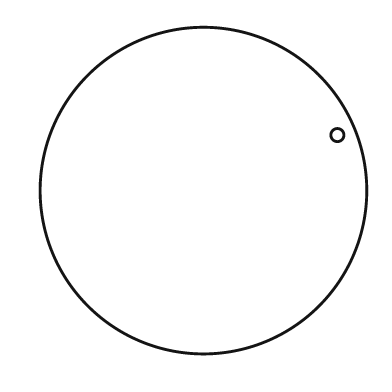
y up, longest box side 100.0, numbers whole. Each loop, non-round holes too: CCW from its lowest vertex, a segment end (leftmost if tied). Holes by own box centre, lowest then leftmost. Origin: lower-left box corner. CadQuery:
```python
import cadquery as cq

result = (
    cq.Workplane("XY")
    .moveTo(50.0, 50.0)
    .circle(50.0)
    .moveTo(91.0, 67.0)
    .circle(2.0)
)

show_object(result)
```